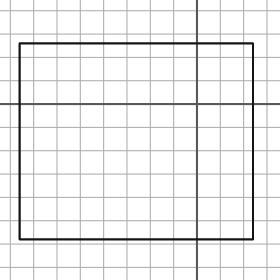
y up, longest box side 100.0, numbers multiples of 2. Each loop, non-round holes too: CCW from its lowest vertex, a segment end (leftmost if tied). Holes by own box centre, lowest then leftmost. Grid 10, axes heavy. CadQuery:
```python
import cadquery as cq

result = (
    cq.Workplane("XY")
    .moveTo(-76.0, -58.0)
    .lineTo(24.0, -58.0)
    .lineTo(24.0, 26.0)
    .lineTo(-76.0, 26.0)
    .close()
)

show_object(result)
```